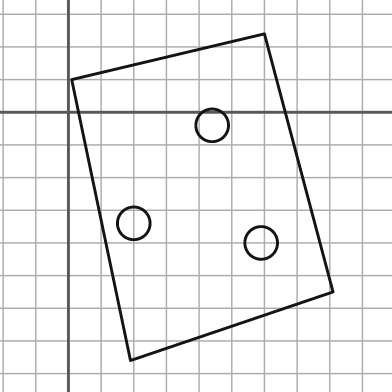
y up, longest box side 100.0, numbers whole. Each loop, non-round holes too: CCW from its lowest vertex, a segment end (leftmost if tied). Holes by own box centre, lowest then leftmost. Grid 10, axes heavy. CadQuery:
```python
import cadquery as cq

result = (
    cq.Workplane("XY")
    .moveTo(19.0, -76.0)
    .lineTo(81.0, -55.0)
    .lineTo(60.0, 24.0)
    .lineTo(1.0, 10.0)
    .close()
    .moveTo(59.0, -40.0)
    .circle(5.0)
    .moveTo(20.0, -34.0)
    .circle(5.0)
    .moveTo(44.0, -4.0)
    .circle(5.0)
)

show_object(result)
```